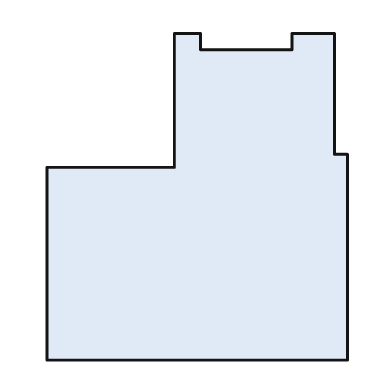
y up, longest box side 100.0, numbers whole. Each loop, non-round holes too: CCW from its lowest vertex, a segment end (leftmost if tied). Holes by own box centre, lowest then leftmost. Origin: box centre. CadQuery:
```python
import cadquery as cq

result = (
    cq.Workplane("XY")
    .moveTo(-46.0, -50.0)
    .lineTo(46.0, -50.0)
    .lineTo(46.0, 13.0)
    .lineTo(42.0, 13.0)
    .lineTo(42.0, 50.0)
    .lineTo(29.0, 50.0)
    .lineTo(29.0, 45.0)
    .lineTo(1.0, 45.0)
    .lineTo(1.0, 50.0)
    .lineTo(-7.0, 50.0)
    .lineTo(-7.0, 9.0)
    .lineTo(-46.0, 9.0)
    .close()
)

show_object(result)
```